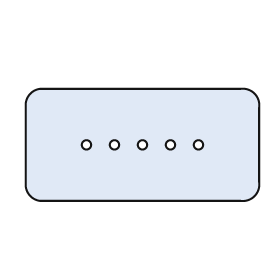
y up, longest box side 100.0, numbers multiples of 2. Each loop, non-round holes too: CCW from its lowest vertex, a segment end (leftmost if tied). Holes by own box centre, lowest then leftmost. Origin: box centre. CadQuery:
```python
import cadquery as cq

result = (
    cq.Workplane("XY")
    .moveTo(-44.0, -24.0)
    .lineTo(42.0, -24.0)
    .threePointArc((48.0, -22.0), (50.0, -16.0))
    .lineTo(50.0, 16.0)
    .threePointArc((48.0, 22.0), (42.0, 24.0))
    .lineTo(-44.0, 24.0)
    .threePointArc((-48.0, 22.0), (-50.0, 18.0))
    .lineTo(-50.0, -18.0)
    .threePointArc((-48.0, -22.0), (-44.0, -24.0))
    .close()
    .moveTo(-24.0, 0.0)
    .circle(2.0)
    .moveTo(-12.0, 0.0)
    .circle(2.0)
    .moveTo(0.0, 0.0)
    .circle(2.0)
    .moveTo(12.0, 0.0)
    .circle(2.0)
    .moveTo(24.0, 0.0)
    .circle(2.0)
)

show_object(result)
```